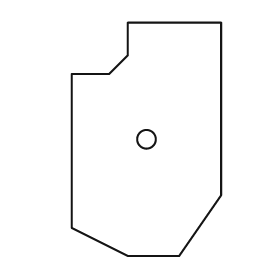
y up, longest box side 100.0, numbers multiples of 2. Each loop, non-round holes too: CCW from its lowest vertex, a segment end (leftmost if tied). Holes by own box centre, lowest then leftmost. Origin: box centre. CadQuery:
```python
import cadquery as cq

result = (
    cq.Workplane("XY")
    .moveTo(-8.0, -50.0)
    .lineTo(14.0, -50.0)
    .lineTo(32.0, -24.0)
    .lineTo(32.0, 50.0)
    .lineTo(-8.0, 50.0)
    .lineTo(-8.0, 36.0)
    .lineTo(-16.0, 28.0)
    .lineTo(-32.0, 28.0)
    .lineTo(-32.0, -38.0)
    .close()
    .moveTo(0.0, 0.0)
    .circle(4.0)
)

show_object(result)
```